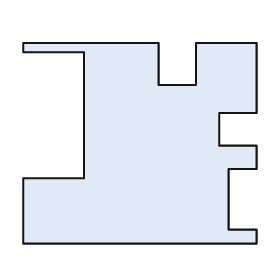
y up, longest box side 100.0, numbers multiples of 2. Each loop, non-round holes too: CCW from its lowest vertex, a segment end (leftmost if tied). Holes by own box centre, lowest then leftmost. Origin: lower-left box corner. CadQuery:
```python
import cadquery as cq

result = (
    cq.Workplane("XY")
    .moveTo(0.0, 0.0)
    .lineTo(100.0, 0.0)
    .lineTo(100.0, 6.0)
    .lineTo(88.0, 6.0)
    .lineTo(88.0, 32.0)
    .lineTo(100.0, 32.0)
    .lineTo(100.0, 42.0)
    .lineTo(84.0, 42.0)
    .lineTo(84.0, 56.0)
    .lineTo(100.0, 56.0)
    .lineTo(100.0, 86.0)
    .lineTo(74.0, 86.0)
    .lineTo(74.0, 68.0)
    .lineTo(58.0, 68.0)
    .lineTo(58.0, 86.0)
    .lineTo(0.0, 86.0)
    .lineTo(0.0, 82.0)
    .lineTo(26.0, 82.0)
    .lineTo(26.0, 28.0)
    .lineTo(0.0, 28.0)
    .close()
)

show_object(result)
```